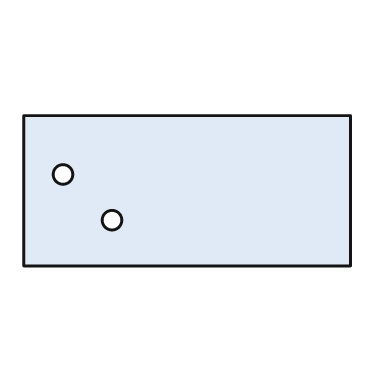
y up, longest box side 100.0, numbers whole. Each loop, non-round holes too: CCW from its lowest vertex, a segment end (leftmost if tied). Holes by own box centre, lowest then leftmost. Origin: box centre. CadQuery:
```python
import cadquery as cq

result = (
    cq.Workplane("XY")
    .moveTo(-50.0, -23.0)
    .lineTo(50.0, -23.0)
    .lineTo(50.0, 23.0)
    .lineTo(-50.0, 23.0)
    .close()
    .moveTo(-23.0, -9.0)
    .circle(3.0)
    .moveTo(-38.0, 5.0)
    .circle(3.0)
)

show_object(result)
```